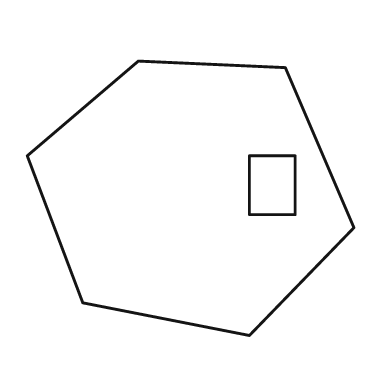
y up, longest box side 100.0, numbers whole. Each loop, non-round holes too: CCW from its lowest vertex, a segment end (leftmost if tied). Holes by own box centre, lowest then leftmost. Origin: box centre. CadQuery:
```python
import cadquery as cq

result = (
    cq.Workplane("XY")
    .moveTo(18.0, -42.0)
    .lineTo(50.0, -9.0)
    .lineTo(29.0, 40.0)
    .lineTo(-16.0, 42.0)
    .lineTo(-50.0, 13.0)
    .lineTo(-33.0, -32.0)
    .close()
    .moveTo(18.0, -5.0)
    .lineTo(32.0, -5.0)
    .lineTo(32.0, 13.0)
    .lineTo(18.0, 13.0)
    .close()
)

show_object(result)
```